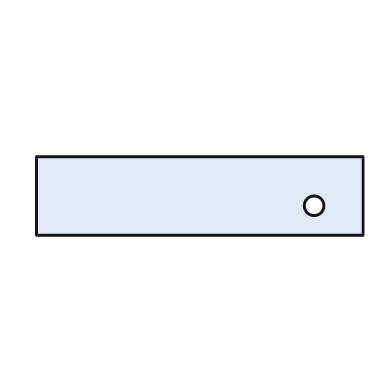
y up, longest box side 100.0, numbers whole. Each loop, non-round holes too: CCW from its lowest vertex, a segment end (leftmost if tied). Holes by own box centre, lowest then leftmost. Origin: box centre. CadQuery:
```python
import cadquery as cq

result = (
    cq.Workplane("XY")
    .moveTo(-50.0, -12.0)
    .lineTo(50.0, -12.0)
    .lineTo(50.0, 12.0)
    .lineTo(-50.0, 12.0)
    .close()
    .moveTo(35.0, -3.0)
    .circle(3.0)
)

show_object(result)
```